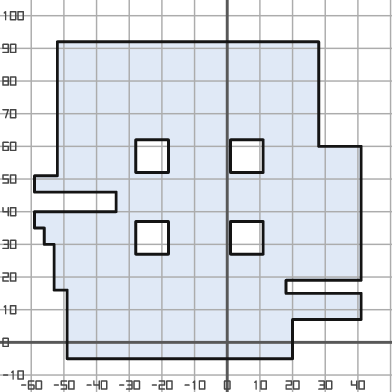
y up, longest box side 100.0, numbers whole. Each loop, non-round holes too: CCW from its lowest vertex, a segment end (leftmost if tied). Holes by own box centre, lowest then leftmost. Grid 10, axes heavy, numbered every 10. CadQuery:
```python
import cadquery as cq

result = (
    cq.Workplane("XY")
    .moveTo(-49.0, -5.0)
    .lineTo(20.0, -5.0)
    .lineTo(20.0, 7.0)
    .lineTo(41.0, 7.0)
    .lineTo(41.0, 15.0)
    .lineTo(18.0, 15.0)
    .lineTo(18.0, 19.0)
    .lineTo(41.0, 19.0)
    .lineTo(41.0, 60.0)
    .lineTo(28.0, 60.0)
    .lineTo(28.0, 92.0)
    .lineTo(-52.0, 92.0)
    .lineTo(-52.0, 51.0)
    .lineTo(-59.0, 51.0)
    .lineTo(-59.0, 46.0)
    .lineTo(-34.0, 46.0)
    .lineTo(-34.0, 40.0)
    .lineTo(-59.0, 40.0)
    .lineTo(-59.0, 35.0)
    .lineTo(-56.0, 35.0)
    .lineTo(-56.0, 30.0)
    .lineTo(-53.0, 30.0)
    .lineTo(-53.0, 16.0)
    .lineTo(-49.0, 16.0)
    .close()
    .moveTo(-28.0, 27.0)
    .lineTo(-18.0, 27.0)
    .lineTo(-18.0, 37.0)
    .lineTo(-28.0, 37.0)
    .close()
    .moveTo(1.0, 27.0)
    .lineTo(11.0, 27.0)
    .lineTo(11.0, 37.0)
    .lineTo(1.0, 37.0)
    .close()
    .moveTo(-28.0, 52.0)
    .lineTo(-18.0, 52.0)
    .lineTo(-18.0, 62.0)
    .lineTo(-28.0, 62.0)
    .close()
    .moveTo(1.0, 52.0)
    .lineTo(11.0, 52.0)
    .lineTo(11.0, 62.0)
    .lineTo(1.0, 62.0)
    .close()
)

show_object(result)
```